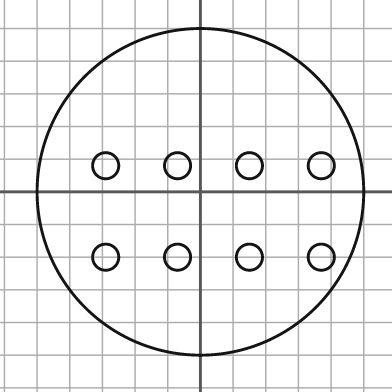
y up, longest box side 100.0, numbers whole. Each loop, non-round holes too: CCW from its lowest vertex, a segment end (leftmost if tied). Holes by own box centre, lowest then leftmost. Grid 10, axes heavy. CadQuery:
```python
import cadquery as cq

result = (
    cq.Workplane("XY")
    .moveTo(0.0, 0.0)
    .circle(50.0)
    .moveTo(-29.0, -20.0)
    .circle(4.0)
    .moveTo(-7.0, -20.0)
    .circle(4.0)
    .moveTo(15.0, -20.0)
    .circle(4.0)
    .moveTo(37.0, -20.0)
    .circle(4.0)
    .moveTo(-29.0, 8.0)
    .circle(4.0)
    .moveTo(-7.0, 8.0)
    .circle(4.0)
    .moveTo(15.0, 8.0)
    .circle(4.0)
    .moveTo(37.0, 8.0)
    .circle(4.0)
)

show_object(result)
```